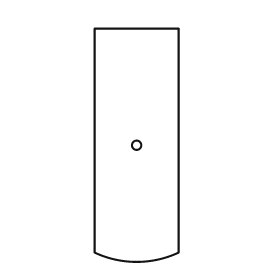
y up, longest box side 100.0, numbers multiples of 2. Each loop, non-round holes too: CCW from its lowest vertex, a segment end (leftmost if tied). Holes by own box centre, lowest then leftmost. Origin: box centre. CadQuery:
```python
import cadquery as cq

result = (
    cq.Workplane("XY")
    .moveTo(-18.0, -46.0)
    .threePointArc((0.0, -50.0), (18.0, -46.0))
    .lineTo(18.0, 50.0)
    .lineTo(-18.0, 50.0)
    .close()
    .moveTo(0.0, 0.0)
    .circle(2.0)
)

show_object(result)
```